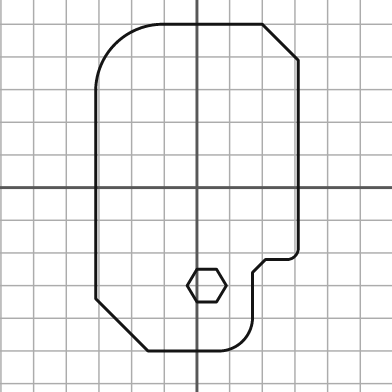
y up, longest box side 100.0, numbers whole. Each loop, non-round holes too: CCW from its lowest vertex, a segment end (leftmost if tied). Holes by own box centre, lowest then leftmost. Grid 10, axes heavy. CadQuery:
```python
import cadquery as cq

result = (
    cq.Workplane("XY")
    .moveTo(-15.0, -50.0)
    .lineTo(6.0, -50.0)
    .threePointArc((14.0, -47.0), (17.0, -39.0))
    .lineTo(17.0, -26.0)
    .lineTo(21.0, -22.0)
    .lineTo(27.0, -22.0)
    .threePointArc((30.0, -21.0), (31.0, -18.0))
    .lineTo(31.0, 39.0)
    .lineTo(20.0, 50.0)
    .lineTo(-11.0, 50.0)
    .threePointArc((-25.0, 44.0), (-31.0, 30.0))
    .lineTo(-31.0, -34.0)
    .close()
    .moveTo(0.0, -35.0)
    .lineTo(6.0, -35.0)
    .lineTo(9.0, -30.0)
    .lineTo(6.0, -25.0)
    .lineTo(0.0, -25.0)
    .lineTo(-3.0, -30.0)
    .close()
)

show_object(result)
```